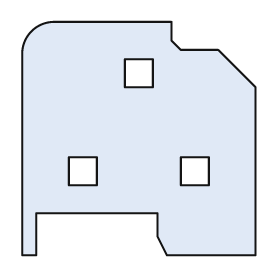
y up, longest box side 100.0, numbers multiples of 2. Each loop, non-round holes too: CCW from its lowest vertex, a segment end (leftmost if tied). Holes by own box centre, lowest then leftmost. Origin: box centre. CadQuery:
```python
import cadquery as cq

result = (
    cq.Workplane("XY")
    .moveTo(-50.0, -50.0)
    .lineTo(-44.0, -50.0)
    .lineTo(-44.0, -32.0)
    .lineTo(8.0, -32.0)
    .lineTo(8.0, -42.0)
    .lineTo(12.0, -50.0)
    .lineTo(50.0, -50.0)
    .lineTo(50.0, 22.0)
    .lineTo(34.0, 38.0)
    .lineTo(18.0, 38.0)
    .lineTo(14.0, 42.0)
    .lineTo(14.0, 50.0)
    .lineTo(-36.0, 50.0)
    .threePointArc((-46.0, 46.0), (-50.0, 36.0))
    .close()
    .moveTo(-30.0, -20.0)
    .lineTo(-18.0, -20.0)
    .lineTo(-18.0, -8.0)
    .lineTo(-30.0, -8.0)
    .close()
    .moveTo(18.0, -20.0)
    .lineTo(30.0, -20.0)
    .lineTo(30.0, -8.0)
    .lineTo(18.0, -8.0)
    .close()
    .moveTo(-6.0, 22.0)
    .lineTo(6.0, 22.0)
    .lineTo(6.0, 34.0)
    .lineTo(-6.0, 34.0)
    .close()
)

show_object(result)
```